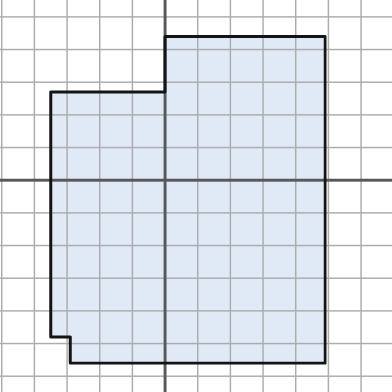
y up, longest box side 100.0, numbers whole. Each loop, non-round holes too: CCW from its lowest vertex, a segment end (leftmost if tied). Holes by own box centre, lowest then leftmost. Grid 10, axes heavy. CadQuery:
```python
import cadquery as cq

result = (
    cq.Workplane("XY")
    .moveTo(-29.0, -56.0)
    .lineTo(49.0, -56.0)
    .lineTo(49.0, 44.0)
    .lineTo(0.0, 44.0)
    .lineTo(0.0, 27.0)
    .lineTo(-35.0, 27.0)
    .lineTo(-35.0, -48.0)
    .lineTo(-29.0, -48.0)
    .close()
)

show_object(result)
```